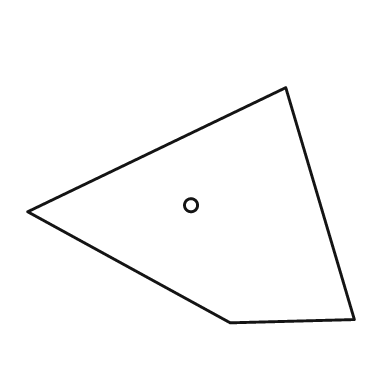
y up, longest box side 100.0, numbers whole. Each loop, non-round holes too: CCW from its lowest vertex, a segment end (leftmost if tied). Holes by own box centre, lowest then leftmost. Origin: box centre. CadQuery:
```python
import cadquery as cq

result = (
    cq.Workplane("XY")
    .moveTo(12.0, -36.0)
    .lineTo(50.0, -35.0)
    .lineTo(29.0, 36.0)
    .lineTo(-50.0, -2.0)
    .close()
    .moveTo(0.0, 0.0)
    .circle(2.0)
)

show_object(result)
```